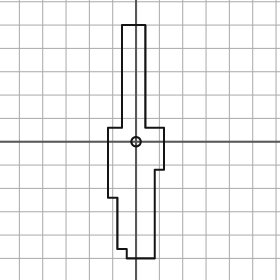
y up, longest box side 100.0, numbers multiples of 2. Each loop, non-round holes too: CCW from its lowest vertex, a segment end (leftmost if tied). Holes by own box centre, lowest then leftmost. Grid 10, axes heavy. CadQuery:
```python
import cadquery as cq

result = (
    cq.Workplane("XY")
    .moveTo(-4.0, -50.0)
    .lineTo(8.0, -50.0)
    .lineTo(8.0, -12.0)
    .lineTo(12.0, -12.0)
    .lineTo(12.0, 6.0)
    .lineTo(4.0, 6.0)
    .lineTo(4.0, 50.0)
    .lineTo(-6.0, 50.0)
    .lineTo(-6.0, 6.0)
    .lineTo(-12.0, 6.0)
    .lineTo(-12.0, -24.0)
    .lineTo(-8.0, -24.0)
    .lineTo(-8.0, -46.0)
    .lineTo(-4.0, -46.0)
    .close()
    .moveTo(0.0, 0.0)
    .circle(2.0)
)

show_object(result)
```